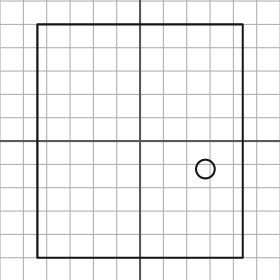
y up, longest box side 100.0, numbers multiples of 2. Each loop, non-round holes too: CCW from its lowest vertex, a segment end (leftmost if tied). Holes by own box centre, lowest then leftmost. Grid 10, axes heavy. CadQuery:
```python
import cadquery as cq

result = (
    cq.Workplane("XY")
    .moveTo(-44.0, -50.0)
    .lineTo(44.0, -50.0)
    .lineTo(44.0, 50.0)
    .lineTo(-44.0, 50.0)
    .close()
    .moveTo(28.0, -12.0)
    .circle(4.0)
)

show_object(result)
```